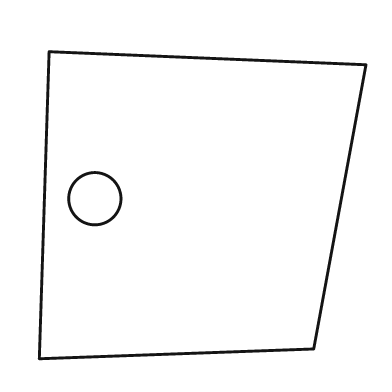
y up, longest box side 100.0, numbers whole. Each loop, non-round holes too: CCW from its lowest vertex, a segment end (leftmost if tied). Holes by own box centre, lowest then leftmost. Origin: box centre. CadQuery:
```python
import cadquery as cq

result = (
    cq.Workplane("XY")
    .moveTo(-50.0, -47.0)
    .lineTo(34.0, -44.0)
    .lineTo(50.0, 43.0)
    .lineTo(-47.0, 47.0)
    .close()
    .moveTo(-33.0, 2.0)
    .circle(8.0)
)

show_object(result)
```